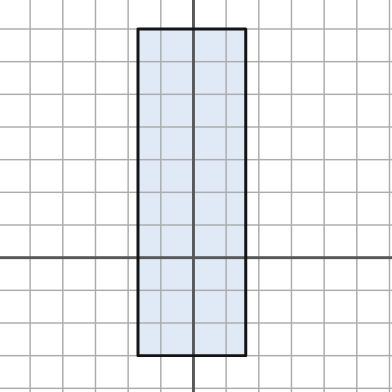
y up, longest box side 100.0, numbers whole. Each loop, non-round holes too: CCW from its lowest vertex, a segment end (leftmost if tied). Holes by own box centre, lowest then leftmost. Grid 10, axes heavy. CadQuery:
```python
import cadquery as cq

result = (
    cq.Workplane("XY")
    .moveTo(-17.0, -30.0)
    .lineTo(16.0, -30.0)
    .lineTo(16.0, 70.0)
    .lineTo(-17.0, 70.0)
    .close()
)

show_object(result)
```